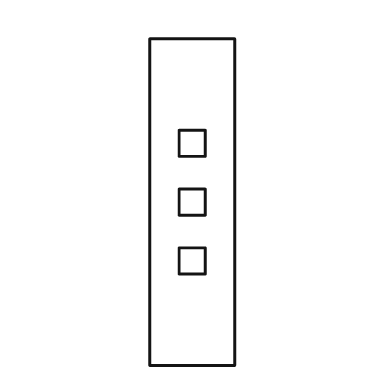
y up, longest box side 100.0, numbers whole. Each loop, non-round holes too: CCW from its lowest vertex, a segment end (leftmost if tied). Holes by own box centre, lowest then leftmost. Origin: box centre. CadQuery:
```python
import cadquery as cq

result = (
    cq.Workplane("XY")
    .moveTo(-13.0, -50.0)
    .lineTo(13.0, -50.0)
    .lineTo(13.0, 50.0)
    .lineTo(-13.0, 50.0)
    .close()
    .moveTo(-4.0, -22.0)
    .lineTo(4.0, -22.0)
    .lineTo(4.0, -14.0)
    .lineTo(-4.0, -14.0)
    .close()
    .moveTo(-4.0, -4.0)
    .lineTo(4.0, -4.0)
    .lineTo(4.0, 4.0)
    .lineTo(-4.0, 4.0)
    .close()
    .moveTo(-4.0, 14.0)
    .lineTo(4.0, 14.0)
    .lineTo(4.0, 22.0)
    .lineTo(-4.0, 22.0)
    .close()
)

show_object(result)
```